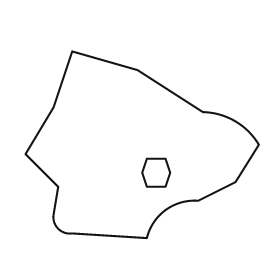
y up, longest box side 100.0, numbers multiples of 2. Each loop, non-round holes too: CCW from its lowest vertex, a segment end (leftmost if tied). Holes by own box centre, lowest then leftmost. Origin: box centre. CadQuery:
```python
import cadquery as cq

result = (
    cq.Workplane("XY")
    .moveTo(2.0, -40.0)
    .threePointArc((10.0, -28.0), (24.0, -24.0))
    .lineTo(40.0, -16.0)
    .lineTo(50.0, 0.0)
    .threePointArc((40.0, 10.0), (26.0, 14.0))
    .lineTo(-2.0, 32.0)
    .lineTo(-30.0, 40.0)
    .lineTo(-38.0, 16.0)
    .lineTo(-50.0, -4.0)
    .lineTo(-36.0, -18.0)
    .lineTo(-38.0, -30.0)
    .threePointArc((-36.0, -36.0), (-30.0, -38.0))
    .close()
    .moveTo(2.0, -18.0)
    .lineTo(10.0, -18.0)
    .lineTo(12.0, -12.0)
    .lineTo(10.0, -6.0)
    .lineTo(2.0, -6.0)
    .lineTo(0.0, -12.0)
    .close()
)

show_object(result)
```